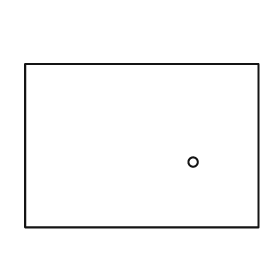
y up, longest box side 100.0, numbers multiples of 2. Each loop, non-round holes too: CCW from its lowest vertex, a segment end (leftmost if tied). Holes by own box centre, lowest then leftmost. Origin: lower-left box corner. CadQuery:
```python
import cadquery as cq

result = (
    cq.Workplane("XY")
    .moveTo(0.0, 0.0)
    .lineTo(100.0, 0.0)
    .lineTo(100.0, 70.0)
    .lineTo(0.0, 70.0)
    .close()
    .moveTo(72.0, 28.0)
    .circle(2.0)
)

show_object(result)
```